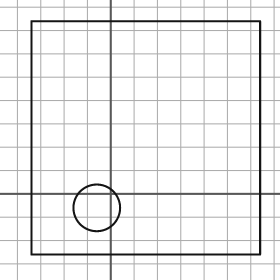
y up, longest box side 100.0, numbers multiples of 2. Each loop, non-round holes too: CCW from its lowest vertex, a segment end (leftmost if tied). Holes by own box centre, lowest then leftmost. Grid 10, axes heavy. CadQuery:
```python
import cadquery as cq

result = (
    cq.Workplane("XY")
    .moveTo(-34.0, -26.0)
    .lineTo(64.0, -26.0)
    .lineTo(64.0, 74.0)
    .lineTo(-34.0, 74.0)
    .close()
    .moveTo(-6.0, -6.0)
    .circle(10.0)
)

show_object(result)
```